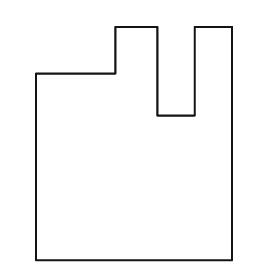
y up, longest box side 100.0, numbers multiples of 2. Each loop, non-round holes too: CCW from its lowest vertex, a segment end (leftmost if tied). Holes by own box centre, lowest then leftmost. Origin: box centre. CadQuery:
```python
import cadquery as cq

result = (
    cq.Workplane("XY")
    .moveTo(-42.0, -50.0)
    .lineTo(42.0, -50.0)
    .lineTo(42.0, 50.0)
    .lineTo(26.0, 50.0)
    .lineTo(26.0, 12.0)
    .lineTo(10.0, 12.0)
    .lineTo(10.0, 50.0)
    .lineTo(-8.0, 50.0)
    .lineTo(-8.0, 30.0)
    .lineTo(-42.0, 30.0)
    .close()
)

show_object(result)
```